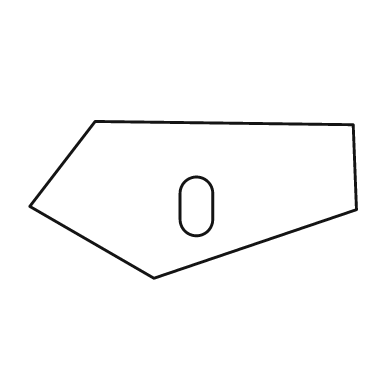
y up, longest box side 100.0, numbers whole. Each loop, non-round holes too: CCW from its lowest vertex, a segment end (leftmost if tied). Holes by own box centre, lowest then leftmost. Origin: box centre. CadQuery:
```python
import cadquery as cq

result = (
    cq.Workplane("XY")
    .moveTo(-12.0, -24.0)
    .lineTo(50.0, -3.0)
    .lineTo(49.0, 23.0)
    .lineTo(-30.0, 24.0)
    .lineTo(-50.0, -2.0)
    .close()
    .moveTo(-4.0, -6.0)
    .threePointArc((1.0, -11.0), (6.0, -6.0))
    .lineTo(6.0, 2.0)
    .threePointArc((1.0, 7.0), (-4.0, 2.0))
    .close()
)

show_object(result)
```